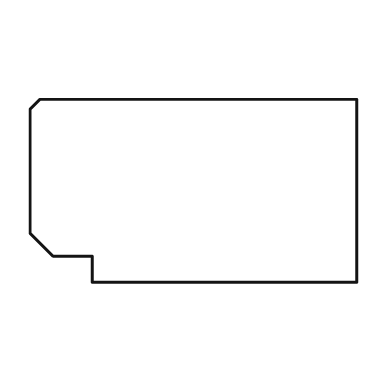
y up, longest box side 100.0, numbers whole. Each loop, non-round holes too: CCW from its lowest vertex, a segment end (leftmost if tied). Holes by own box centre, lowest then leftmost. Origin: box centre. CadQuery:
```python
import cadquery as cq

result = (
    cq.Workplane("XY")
    .moveTo(-31.0, -28.0)
    .lineTo(50.0, -28.0)
    .lineTo(50.0, 28.0)
    .lineTo(-47.0, 28.0)
    .lineTo(-50.0, 25.0)
    .lineTo(-50.0, -13.0)
    .lineTo(-43.0, -20.0)
    .lineTo(-31.0, -20.0)
    .close()
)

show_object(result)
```